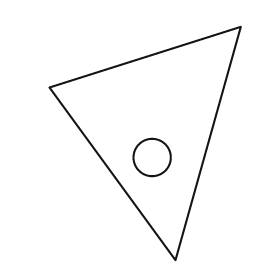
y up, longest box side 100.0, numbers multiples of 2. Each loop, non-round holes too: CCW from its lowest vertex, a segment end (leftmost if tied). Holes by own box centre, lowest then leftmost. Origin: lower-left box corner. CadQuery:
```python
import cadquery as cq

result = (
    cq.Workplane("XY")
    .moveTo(54.0, 0.0)
    .lineTo(82.0, 100.0)
    .lineTo(0.0, 74.0)
    .close()
    .moveTo(44.0, 44.0)
    .circle(8.0)
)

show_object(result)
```